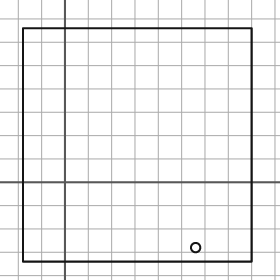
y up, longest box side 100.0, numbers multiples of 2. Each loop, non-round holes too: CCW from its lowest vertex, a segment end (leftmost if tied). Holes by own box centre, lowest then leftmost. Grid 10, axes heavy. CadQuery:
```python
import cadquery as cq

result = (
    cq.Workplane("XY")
    .moveTo(-18.0, -34.0)
    .lineTo(80.0, -34.0)
    .lineTo(80.0, 66.0)
    .lineTo(-18.0, 66.0)
    .close()
    .moveTo(56.0, -28.0)
    .circle(2.0)
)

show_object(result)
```